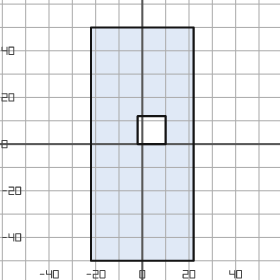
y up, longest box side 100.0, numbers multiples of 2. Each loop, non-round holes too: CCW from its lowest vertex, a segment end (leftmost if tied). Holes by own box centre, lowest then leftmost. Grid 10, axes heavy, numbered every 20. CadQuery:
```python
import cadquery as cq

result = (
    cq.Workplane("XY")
    .moveTo(-22.0, -50.0)
    .lineTo(22.0, -50.0)
    .lineTo(22.0, 50.0)
    .lineTo(-22.0, 50.0)
    .close()
    .moveTo(-2.0, 0.0)
    .lineTo(10.0, 0.0)
    .lineTo(10.0, 12.0)
    .lineTo(-2.0, 12.0)
    .close()
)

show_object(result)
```